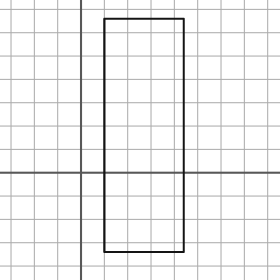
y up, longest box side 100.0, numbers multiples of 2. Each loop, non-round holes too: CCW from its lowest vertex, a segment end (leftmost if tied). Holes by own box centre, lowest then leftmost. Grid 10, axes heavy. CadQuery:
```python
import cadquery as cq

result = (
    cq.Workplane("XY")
    .moveTo(10.0, -34.0)
    .lineTo(44.0, -34.0)
    .lineTo(44.0, 66.0)
    .lineTo(10.0, 66.0)
    .close()
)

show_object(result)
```